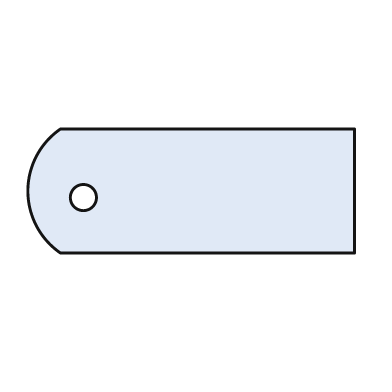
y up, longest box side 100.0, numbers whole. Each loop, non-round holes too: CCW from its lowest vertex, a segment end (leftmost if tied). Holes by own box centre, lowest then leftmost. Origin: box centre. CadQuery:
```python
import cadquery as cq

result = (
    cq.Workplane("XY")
    .moveTo(-40.0, -19.0)
    .lineTo(50.0, -19.0)
    .lineTo(50.0, 19.0)
    .lineTo(-40.0, 19.0)
    .threePointArc((-50.0, 0.0), (-40.0, -19.0))
    .close()
    .moveTo(-33.0, -2.0)
    .circle(4.0)
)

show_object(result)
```